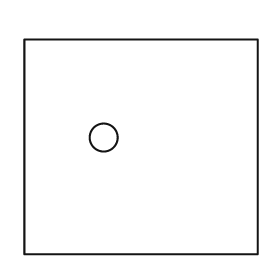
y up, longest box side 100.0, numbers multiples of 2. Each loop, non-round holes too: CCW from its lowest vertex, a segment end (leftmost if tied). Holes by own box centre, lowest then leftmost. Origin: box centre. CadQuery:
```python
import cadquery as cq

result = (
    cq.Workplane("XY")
    .moveTo(-50.0, -46.0)
    .lineTo(50.0, -46.0)
    .lineTo(50.0, 46.0)
    .lineTo(-50.0, 46.0)
    .close()
    .moveTo(-16.0, 4.0)
    .circle(6.0)
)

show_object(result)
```